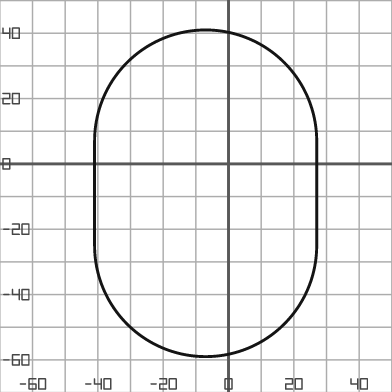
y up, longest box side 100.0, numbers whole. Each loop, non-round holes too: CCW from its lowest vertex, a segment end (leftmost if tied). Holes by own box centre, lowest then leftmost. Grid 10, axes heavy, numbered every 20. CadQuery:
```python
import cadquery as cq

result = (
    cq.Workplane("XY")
    .moveTo(-41.0, -25.0)
    .threePointArc((-7.0, -59.0), (27.0, -25.0))
    .lineTo(27.0, 7.0)
    .threePointArc((-7.0, 41.0), (-41.0, 7.0))
    .close()
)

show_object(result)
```